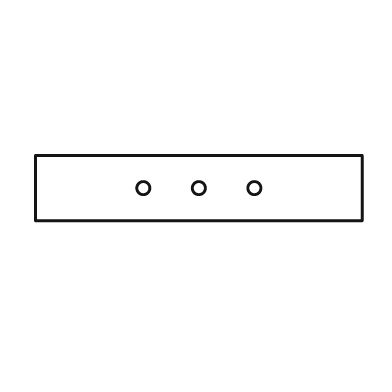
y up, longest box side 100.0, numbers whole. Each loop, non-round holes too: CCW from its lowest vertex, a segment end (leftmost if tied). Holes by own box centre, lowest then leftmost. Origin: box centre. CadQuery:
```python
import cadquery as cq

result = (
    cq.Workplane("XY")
    .moveTo(-50.0, -10.0)
    .lineTo(50.0, -10.0)
    .lineTo(50.0, 10.0)
    .lineTo(-50.0, 10.0)
    .close()
    .moveTo(-17.0, 0.0)
    .circle(2.0)
    .moveTo(0.0, 0.0)
    .circle(2.0)
    .moveTo(17.0, 0.0)
    .circle(2.0)
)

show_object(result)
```